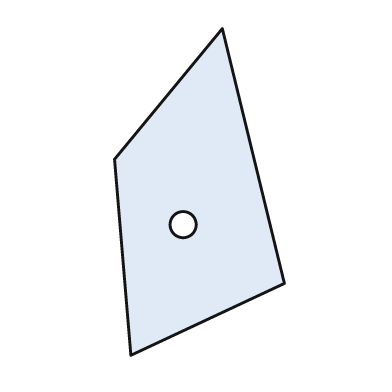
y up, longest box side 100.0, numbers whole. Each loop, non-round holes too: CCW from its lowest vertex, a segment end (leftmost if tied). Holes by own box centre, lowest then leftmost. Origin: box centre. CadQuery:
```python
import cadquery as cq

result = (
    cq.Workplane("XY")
    .moveTo(-21.0, -50.0)
    .lineTo(26.0, -28.0)
    .lineTo(7.0, 50.0)
    .lineTo(-26.0, 10.0)
    .close()
    .moveTo(-5.0, -10.0)
    .circle(4.0)
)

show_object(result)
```